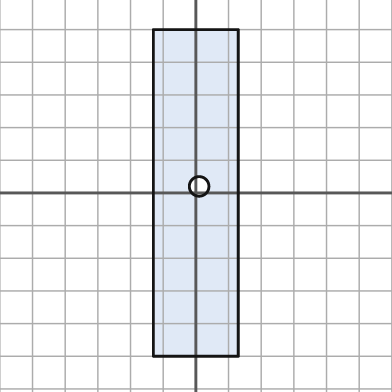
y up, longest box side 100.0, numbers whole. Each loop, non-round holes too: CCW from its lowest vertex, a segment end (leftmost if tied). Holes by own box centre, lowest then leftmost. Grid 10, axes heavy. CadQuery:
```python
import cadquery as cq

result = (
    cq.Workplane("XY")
    .moveTo(-13.0, -50.0)
    .lineTo(13.0, -50.0)
    .lineTo(13.0, 50.0)
    .lineTo(-13.0, 50.0)
    .close()
    .moveTo(1.0, 2.0)
    .circle(3.0)
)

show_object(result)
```